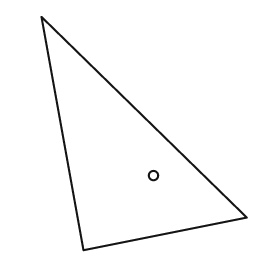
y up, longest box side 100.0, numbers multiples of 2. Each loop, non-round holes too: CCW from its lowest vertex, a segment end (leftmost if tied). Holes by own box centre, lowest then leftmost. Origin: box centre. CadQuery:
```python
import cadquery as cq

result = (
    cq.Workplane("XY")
    .moveTo(-26.0, -50.0)
    .lineTo(44.0, -36.0)
    .lineTo(-44.0, 50.0)
    .close()
    .moveTo(4.0, -18.0)
    .circle(2.0)
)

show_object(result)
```